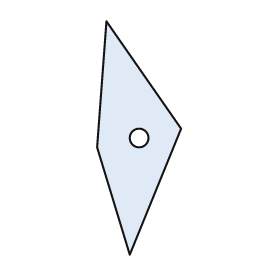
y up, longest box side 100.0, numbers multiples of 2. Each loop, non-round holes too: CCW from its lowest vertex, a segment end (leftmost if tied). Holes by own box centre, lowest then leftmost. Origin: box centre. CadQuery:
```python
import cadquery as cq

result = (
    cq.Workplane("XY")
    .moveTo(-4.0, -50.0)
    .lineTo(18.0, 4.0)
    .lineTo(-14.0, 50.0)
    .lineTo(-18.0, -4.0)
    .close()
    .moveTo(0.0, 0.0)
    .circle(4.0)
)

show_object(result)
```